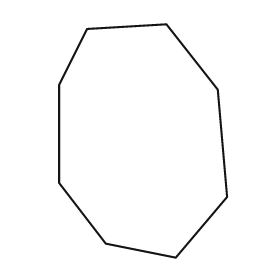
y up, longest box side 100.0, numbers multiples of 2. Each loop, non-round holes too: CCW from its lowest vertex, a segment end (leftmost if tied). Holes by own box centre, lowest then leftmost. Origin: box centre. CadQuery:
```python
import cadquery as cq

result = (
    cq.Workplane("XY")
    .moveTo(14.0, -50.0)
    .lineTo(36.0, -24.0)
    .lineTo(32.0, 22.0)
    .lineTo(10.0, 50.0)
    .lineTo(-24.0, 48.0)
    .lineTo(-36.0, 24.0)
    .lineTo(-36.0, -18.0)
    .lineTo(-16.0, -44.0)
    .close()
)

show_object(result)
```